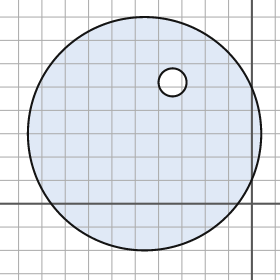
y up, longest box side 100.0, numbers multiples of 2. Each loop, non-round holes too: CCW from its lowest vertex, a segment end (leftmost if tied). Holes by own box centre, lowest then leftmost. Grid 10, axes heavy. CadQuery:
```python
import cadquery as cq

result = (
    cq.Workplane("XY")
    .moveTo(-46.0, 30.0)
    .circle(50.0)
    .moveTo(-34.0, 52.0)
    .circle(6.0)
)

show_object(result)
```